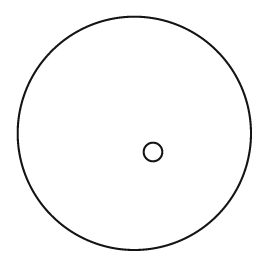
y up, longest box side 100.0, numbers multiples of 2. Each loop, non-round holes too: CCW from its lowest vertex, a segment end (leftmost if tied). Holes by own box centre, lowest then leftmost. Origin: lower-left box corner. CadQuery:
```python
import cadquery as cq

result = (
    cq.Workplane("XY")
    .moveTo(50.0, 50.0)
    .circle(50.0)
    .moveTo(58.0, 42.0)
    .circle(4.0)
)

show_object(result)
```